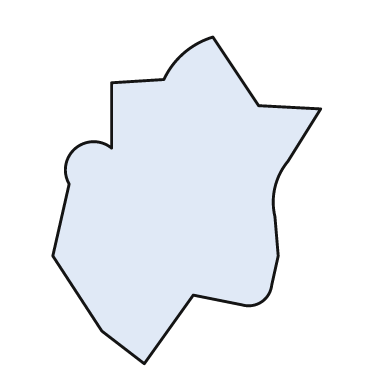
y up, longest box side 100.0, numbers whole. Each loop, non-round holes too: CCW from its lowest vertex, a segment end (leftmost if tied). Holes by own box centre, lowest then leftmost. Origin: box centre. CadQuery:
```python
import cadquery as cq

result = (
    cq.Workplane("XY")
    .moveTo(-13.0, -50.0)
    .lineTo(2.0, -29.0)
    .lineTo(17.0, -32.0)
    .threePointArc((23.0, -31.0), (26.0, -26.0))
    .lineTo(28.0, -17.0)
    .lineTo(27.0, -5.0)
    .threePointArc((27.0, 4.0), (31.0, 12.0))
    .lineTo(41.0, 28.0)
    .lineTo(22.0, 29.0)
    .lineTo(8.0, 50.0)
    .threePointArc((-1.0, 45.0), (-7.0, 37.0))
    .lineTo(-23.0, 36.0)
    .lineTo(-23.0, 16.0)
    .threePointArc((-34.0, 16.0), (-36.0, 5.0))
    .lineTo(-41.0, -17.0)
    .lineTo(-26.0, -40.0)
    .close()
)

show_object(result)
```